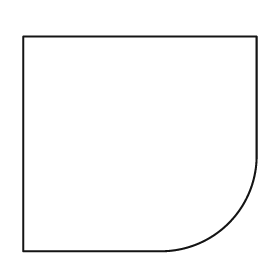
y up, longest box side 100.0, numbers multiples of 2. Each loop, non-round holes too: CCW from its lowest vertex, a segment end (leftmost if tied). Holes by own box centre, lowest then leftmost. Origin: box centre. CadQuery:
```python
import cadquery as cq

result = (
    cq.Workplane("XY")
    .moveTo(-50.0, -46.0)
    .lineTo(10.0, -46.0)
    .threePointArc((38.0, -34.0), (50.0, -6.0))
    .lineTo(50.0, 46.0)
    .lineTo(-50.0, 46.0)
    .close()
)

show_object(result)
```